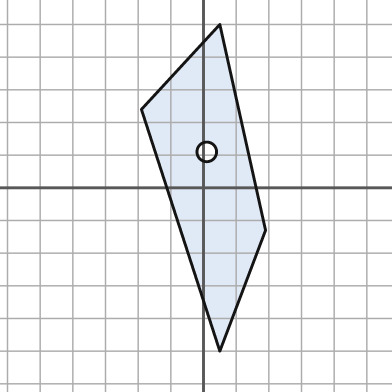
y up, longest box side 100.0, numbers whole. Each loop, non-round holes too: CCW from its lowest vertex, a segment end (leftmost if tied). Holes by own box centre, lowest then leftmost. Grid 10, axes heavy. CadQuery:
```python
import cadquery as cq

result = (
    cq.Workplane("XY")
    .moveTo(5.0, -50.0)
    .lineTo(19.0, -13.0)
    .lineTo(5.0, 50.0)
    .lineTo(-19.0, 24.0)
    .close()
    .moveTo(1.0, 11.0)
    .circle(3.0)
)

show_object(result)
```